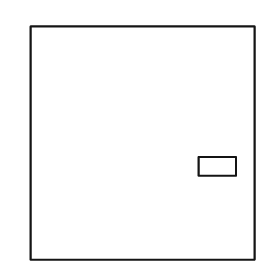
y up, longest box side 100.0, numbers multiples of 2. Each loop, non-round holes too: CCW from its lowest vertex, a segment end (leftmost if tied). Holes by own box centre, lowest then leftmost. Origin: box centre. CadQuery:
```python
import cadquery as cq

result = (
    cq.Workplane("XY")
    .moveTo(-48.0, -50.0)
    .lineTo(48.0, -50.0)
    .lineTo(48.0, 50.0)
    .lineTo(-48.0, 50.0)
    .close()
    .moveTo(24.0, -14.0)
    .lineTo(40.0, -14.0)
    .lineTo(40.0, -6.0)
    .lineTo(24.0, -6.0)
    .close()
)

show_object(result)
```